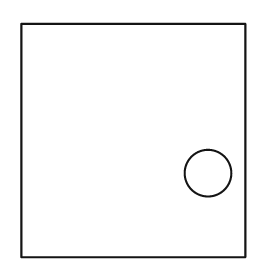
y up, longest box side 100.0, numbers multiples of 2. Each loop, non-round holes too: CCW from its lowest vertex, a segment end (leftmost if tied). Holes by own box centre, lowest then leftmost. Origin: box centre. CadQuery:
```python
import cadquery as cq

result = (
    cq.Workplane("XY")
    .moveTo(-48.0, -50.0)
    .lineTo(48.0, -50.0)
    .lineTo(48.0, 50.0)
    .lineTo(-48.0, 50.0)
    .close()
    .moveTo(32.0, -14.0)
    .circle(10.0)
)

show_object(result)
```